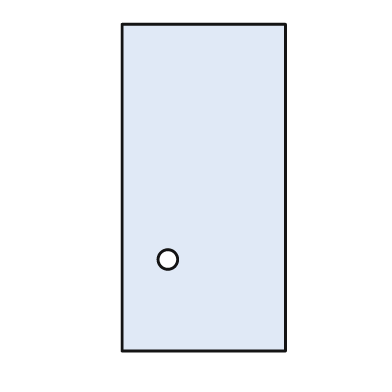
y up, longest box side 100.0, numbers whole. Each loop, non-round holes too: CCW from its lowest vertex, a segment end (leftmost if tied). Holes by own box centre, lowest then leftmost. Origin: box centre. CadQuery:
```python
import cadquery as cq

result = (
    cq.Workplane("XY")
    .moveTo(-25.0, -50.0)
    .lineTo(25.0, -50.0)
    .lineTo(25.0, 50.0)
    .lineTo(-25.0, 50.0)
    .close()
    .moveTo(-11.0, -22.0)
    .circle(3.0)
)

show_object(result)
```